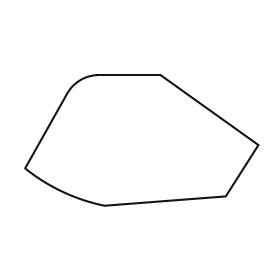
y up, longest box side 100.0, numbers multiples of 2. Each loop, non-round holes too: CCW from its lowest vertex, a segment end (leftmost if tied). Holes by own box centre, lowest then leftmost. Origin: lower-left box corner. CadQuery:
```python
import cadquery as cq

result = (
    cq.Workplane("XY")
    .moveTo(34.0, 0.0)
    .lineTo(86.0, 4.0)
    .lineTo(100.0, 26.0)
    .lineTo(58.0, 56.0)
    .lineTo(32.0, 56.0)
    .threePointArc((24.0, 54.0), (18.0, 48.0))
    .lineTo(0.0, 16.0)
    .threePointArc((16.0, 6.0), (34.0, 0.0))
    .close()
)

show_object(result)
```